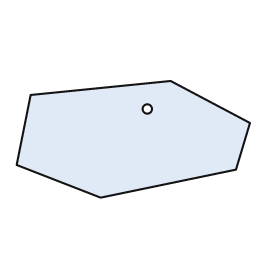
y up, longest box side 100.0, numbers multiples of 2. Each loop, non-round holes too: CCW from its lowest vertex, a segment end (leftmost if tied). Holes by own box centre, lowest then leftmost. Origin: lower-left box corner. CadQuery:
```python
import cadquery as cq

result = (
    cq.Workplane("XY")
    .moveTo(36.0, 0.0)
    .lineTo(94.0, 12.0)
    .lineTo(100.0, 32.0)
    .lineTo(66.0, 50.0)
    .lineTo(6.0, 44.0)
    .lineTo(0.0, 14.0)
    .close()
    .moveTo(56.0, 38.0)
    .circle(2.0)
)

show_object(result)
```